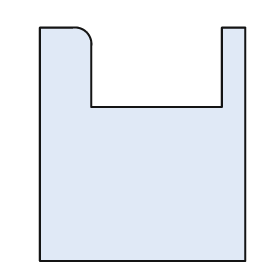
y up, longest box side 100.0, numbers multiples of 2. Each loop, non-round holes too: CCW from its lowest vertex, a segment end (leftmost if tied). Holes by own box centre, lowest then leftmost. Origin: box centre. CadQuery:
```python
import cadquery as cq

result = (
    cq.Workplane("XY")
    .moveTo(-44.0, -50.0)
    .lineTo(44.0, -50.0)
    .lineTo(44.0, 50.0)
    .lineTo(34.0, 50.0)
    .lineTo(34.0, 16.0)
    .lineTo(-22.0, 16.0)
    .lineTo(-22.0, 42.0)
    .threePointArc((-24.0, 48.0), (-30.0, 50.0))
    .lineTo(-44.0, 50.0)
    .close()
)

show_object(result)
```